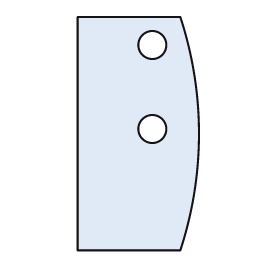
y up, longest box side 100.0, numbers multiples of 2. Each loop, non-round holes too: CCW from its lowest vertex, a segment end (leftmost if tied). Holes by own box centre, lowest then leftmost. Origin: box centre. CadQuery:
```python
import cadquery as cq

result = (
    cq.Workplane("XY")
    .moveTo(-26.0, -50.0)
    .lineTo(18.0, -50.0)
    .threePointArc((26.0, 0.0), (18.0, 50.0))
    .lineTo(-26.0, 50.0)
    .close()
    .moveTo(6.0, 2.0)
    .circle(6.0)
    .moveTo(6.0, 38.0)
    .circle(6.0)
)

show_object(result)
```